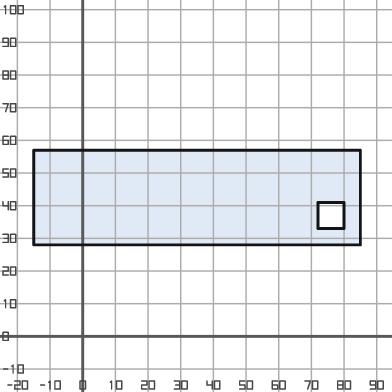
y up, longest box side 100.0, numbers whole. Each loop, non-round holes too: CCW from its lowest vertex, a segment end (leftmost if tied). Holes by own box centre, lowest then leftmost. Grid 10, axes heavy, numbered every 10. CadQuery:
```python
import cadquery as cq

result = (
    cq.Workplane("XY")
    .moveTo(-15.0, 28.0)
    .lineTo(85.0, 28.0)
    .lineTo(85.0, 57.0)
    .lineTo(-15.0, 57.0)
    .close()
    .moveTo(72.0, 33.0)
    .lineTo(80.0, 33.0)
    .lineTo(80.0, 41.0)
    .lineTo(72.0, 41.0)
    .close()
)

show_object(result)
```